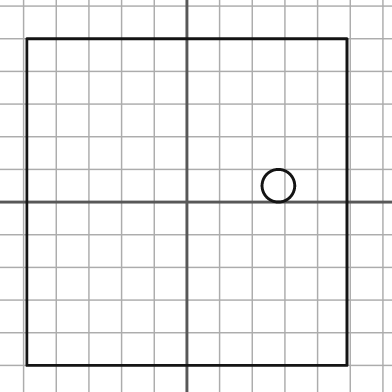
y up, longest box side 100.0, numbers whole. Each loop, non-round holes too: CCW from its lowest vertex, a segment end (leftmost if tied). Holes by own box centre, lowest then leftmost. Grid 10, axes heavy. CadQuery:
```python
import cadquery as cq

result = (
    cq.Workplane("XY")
    .moveTo(-49.0, -50.0)
    .lineTo(49.0, -50.0)
    .lineTo(49.0, 50.0)
    .lineTo(-49.0, 50.0)
    .close()
    .moveTo(28.0, 5.0)
    .circle(5.0)
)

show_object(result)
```